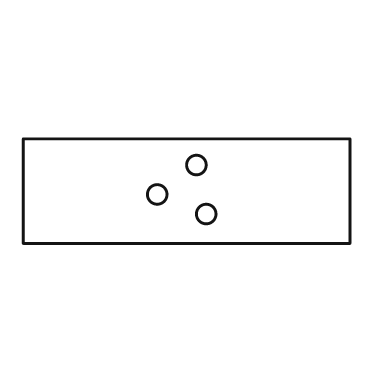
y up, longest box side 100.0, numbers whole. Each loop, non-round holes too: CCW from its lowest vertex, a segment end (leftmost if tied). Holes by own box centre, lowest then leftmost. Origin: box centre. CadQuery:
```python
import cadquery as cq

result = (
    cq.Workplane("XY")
    .moveTo(-50.0, -16.0)
    .lineTo(50.0, -16.0)
    .lineTo(50.0, 16.0)
    .lineTo(-50.0, 16.0)
    .close()
    .moveTo(6.0, -7.0)
    .circle(3.0)
    .moveTo(-9.0, -1.0)
    .circle(3.0)
    .moveTo(3.0, 8.0)
    .circle(3.0)
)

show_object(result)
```